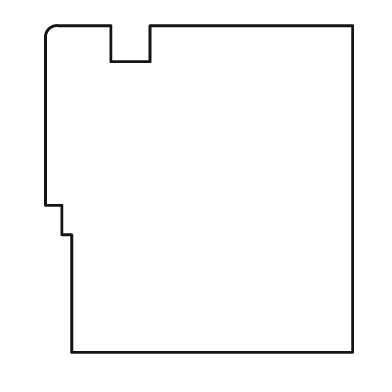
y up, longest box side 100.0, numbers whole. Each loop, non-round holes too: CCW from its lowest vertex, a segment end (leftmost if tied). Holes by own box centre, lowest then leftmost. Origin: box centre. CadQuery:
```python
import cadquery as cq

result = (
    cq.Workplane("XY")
    .moveTo(-39.0, -50.0)
    .lineTo(47.0, -50.0)
    .lineTo(47.0, 50.0)
    .lineTo(-15.0, 50.0)
    .lineTo(-15.0, 39.0)
    .lineTo(-27.0, 39.0)
    .lineTo(-27.0, 50.0)
    .lineTo(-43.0, 50.0)
    .threePointArc((-46.0, 49.0), (-47.0, 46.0))
    .lineTo(-47.0, -5.0)
    .lineTo(-42.0, -5.0)
    .lineTo(-42.0, -14.0)
    .lineTo(-39.0, -14.0)
    .close()
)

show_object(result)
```